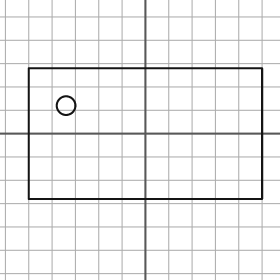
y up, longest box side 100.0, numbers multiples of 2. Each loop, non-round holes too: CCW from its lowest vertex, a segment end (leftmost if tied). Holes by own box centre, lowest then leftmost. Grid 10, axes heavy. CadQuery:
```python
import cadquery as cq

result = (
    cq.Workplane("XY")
    .moveTo(-50.0, -28.0)
    .lineTo(50.0, -28.0)
    .lineTo(50.0, 28.0)
    .lineTo(-50.0, 28.0)
    .close()
    .moveTo(-34.0, 12.0)
    .circle(4.0)
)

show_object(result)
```